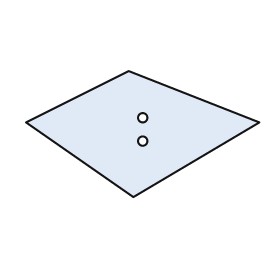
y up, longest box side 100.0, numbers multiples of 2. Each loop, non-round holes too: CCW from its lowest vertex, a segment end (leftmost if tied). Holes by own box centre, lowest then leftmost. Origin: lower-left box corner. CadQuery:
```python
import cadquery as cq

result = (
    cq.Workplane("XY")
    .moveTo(46.0, 0.0)
    .lineTo(100.0, 32.0)
    .lineTo(44.0, 54.0)
    .lineTo(0.0, 32.0)
    .close()
    .moveTo(50.0, 24.0)
    .circle(2.0)
    .moveTo(50.0, 34.0)
    .circle(2.0)
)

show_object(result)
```